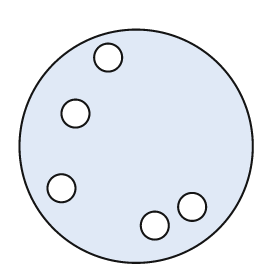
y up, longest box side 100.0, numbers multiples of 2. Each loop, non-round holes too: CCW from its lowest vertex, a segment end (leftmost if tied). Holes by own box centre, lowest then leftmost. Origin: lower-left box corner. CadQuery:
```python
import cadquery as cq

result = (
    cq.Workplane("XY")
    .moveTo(50.0, 50.0)
    .circle(50.0)
    .moveTo(58.0, 16.0)
    .circle(6.0)
    .moveTo(74.0, 24.0)
    .circle(6.0)
    .moveTo(18.0, 32.0)
    .circle(6.0)
    .moveTo(24.0, 64.0)
    .circle(6.0)
    .moveTo(38.0, 88.0)
    .circle(6.0)
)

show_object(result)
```